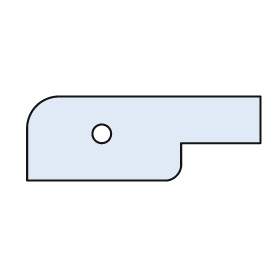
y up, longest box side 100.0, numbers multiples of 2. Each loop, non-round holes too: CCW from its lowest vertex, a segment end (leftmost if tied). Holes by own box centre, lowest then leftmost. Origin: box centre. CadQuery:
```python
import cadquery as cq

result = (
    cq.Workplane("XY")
    .moveTo(-50.0, -18.0)
    .lineTo(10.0, -18.0)
    .threePointArc((14.0, -16.0), (16.0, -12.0))
    .lineTo(16.0, -2.0)
    .lineTo(50.0, -2.0)
    .lineTo(50.0, 18.0)
    .lineTo(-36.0, 18.0)
    .threePointArc((-46.0, 14.0), (-50.0, 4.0))
    .close()
    .moveTo(-18.0, 2.0)
    .circle(4.0)
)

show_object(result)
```